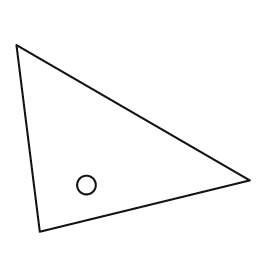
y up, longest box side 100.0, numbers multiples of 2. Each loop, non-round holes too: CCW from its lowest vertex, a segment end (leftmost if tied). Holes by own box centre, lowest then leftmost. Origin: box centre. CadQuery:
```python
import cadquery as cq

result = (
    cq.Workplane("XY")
    .moveTo(-40.0, -40.0)
    .lineTo(50.0, -18.0)
    .lineTo(-50.0, 40.0)
    .close()
    .moveTo(-20.0, -20.0)
    .circle(4.0)
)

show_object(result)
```